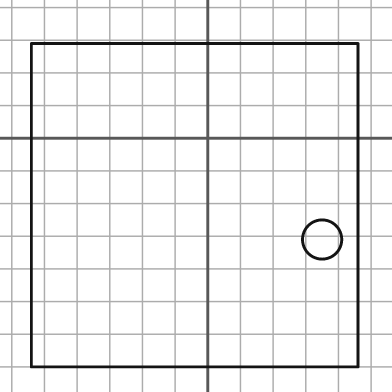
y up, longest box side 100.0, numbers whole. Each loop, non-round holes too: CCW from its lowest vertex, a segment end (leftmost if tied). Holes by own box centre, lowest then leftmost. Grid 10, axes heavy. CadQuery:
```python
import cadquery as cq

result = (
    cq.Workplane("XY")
    .moveTo(-54.0, -70.0)
    .lineTo(46.0, -70.0)
    .lineTo(46.0, 29.0)
    .lineTo(-54.0, 29.0)
    .close()
    .moveTo(35.0, -31.0)
    .circle(6.0)
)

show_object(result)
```